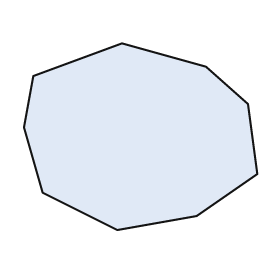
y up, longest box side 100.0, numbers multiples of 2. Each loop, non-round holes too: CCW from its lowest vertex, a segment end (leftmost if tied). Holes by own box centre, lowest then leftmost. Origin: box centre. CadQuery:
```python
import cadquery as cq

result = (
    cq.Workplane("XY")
    .moveTo(-10.0, -40.0)
    .lineTo(24.0, -34.0)
    .lineTo(50.0, -16.0)
    .lineTo(46.0, 14.0)
    .lineTo(28.0, 30.0)
    .lineTo(-8.0, 40.0)
    .lineTo(-46.0, 26.0)
    .lineTo(-50.0, 4.0)
    .lineTo(-42.0, -24.0)
    .close()
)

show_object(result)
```